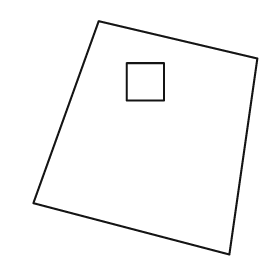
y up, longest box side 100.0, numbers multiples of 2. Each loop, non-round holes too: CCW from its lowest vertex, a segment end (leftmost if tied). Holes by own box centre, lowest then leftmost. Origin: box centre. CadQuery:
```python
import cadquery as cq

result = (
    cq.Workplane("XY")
    .moveTo(36.0, -50.0)
    .lineTo(48.0, 34.0)
    .lineTo(-20.0, 50.0)
    .lineTo(-48.0, -28.0)
    .close()
    .moveTo(-8.0, 16.0)
    .lineTo(8.0, 16.0)
    .lineTo(8.0, 32.0)
    .lineTo(-8.0, 32.0)
    .close()
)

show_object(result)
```